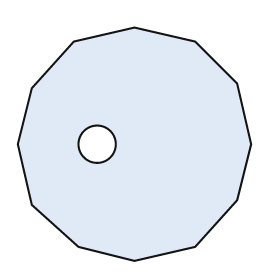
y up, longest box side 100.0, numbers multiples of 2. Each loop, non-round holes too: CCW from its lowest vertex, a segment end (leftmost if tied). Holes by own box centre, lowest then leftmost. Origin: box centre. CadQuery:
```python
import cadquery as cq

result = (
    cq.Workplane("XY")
    .moveTo(0.0, -50.0)
    .lineTo(26.0, -44.0)
    .lineTo(44.0, -24.0)
    .lineTo(50.0, 0.0)
    .lineTo(44.0, 26.0)
    .lineTo(26.0, 44.0)
    .lineTo(0.0, 50.0)
    .lineTo(-26.0, 44.0)
    .lineTo(-44.0, 24.0)
    .lineTo(-50.0, 0.0)
    .lineTo(-44.0, -26.0)
    .lineTo(-24.0, -44.0)
    .close()
    .moveTo(-16.0, 0.0)
    .circle(8.0)
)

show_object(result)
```